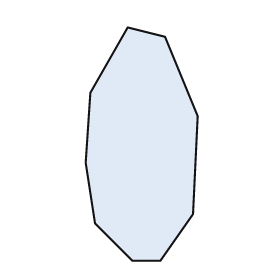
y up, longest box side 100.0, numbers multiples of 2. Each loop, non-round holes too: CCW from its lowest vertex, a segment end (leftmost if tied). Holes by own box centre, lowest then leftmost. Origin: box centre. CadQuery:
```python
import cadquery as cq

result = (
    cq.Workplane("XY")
    .moveTo(-4.0, -50.0)
    .lineTo(8.0, -50.0)
    .lineTo(22.0, -30.0)
    .lineTo(24.0, 12.0)
    .lineTo(10.0, 46.0)
    .lineTo(-6.0, 50.0)
    .lineTo(-22.0, 22.0)
    .lineTo(-24.0, -8.0)
    .lineTo(-20.0, -34.0)
    .close()
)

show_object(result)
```